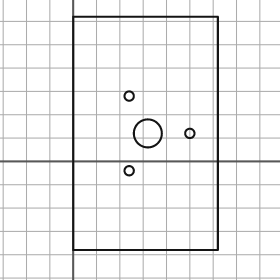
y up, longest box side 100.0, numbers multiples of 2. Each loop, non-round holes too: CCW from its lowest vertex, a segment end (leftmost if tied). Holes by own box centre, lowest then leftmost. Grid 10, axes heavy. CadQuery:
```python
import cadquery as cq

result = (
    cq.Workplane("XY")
    .moveTo(0.0, -38.0)
    .lineTo(62.0, -38.0)
    .lineTo(62.0, 62.0)
    .lineTo(0.0, 62.0)
    .close()
    .moveTo(24.0, -4.0)
    .circle(2.0)
    .moveTo(32.0, 12.0)
    .circle(6.0)
    .moveTo(50.0, 12.0)
    .circle(2.0)
    .moveTo(24.0, 28.0)
    .circle(2.0)
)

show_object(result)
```